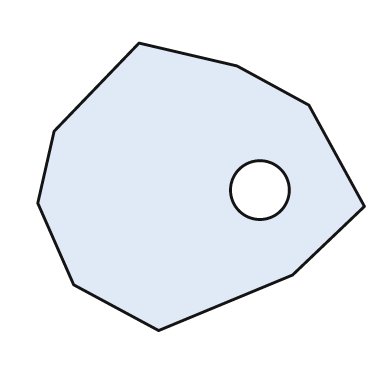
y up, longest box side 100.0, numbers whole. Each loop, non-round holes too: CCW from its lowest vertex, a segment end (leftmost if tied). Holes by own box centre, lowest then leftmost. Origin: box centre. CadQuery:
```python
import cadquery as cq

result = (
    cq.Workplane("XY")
    .moveTo(-13.0, -44.0)
    .lineTo(28.0, -27.0)
    .lineTo(50.0, -6.0)
    .lineTo(33.0, 25.0)
    .lineTo(11.0, 37.0)
    .lineTo(-19.0, 44.0)
    .lineTo(-45.0, 17.0)
    .lineTo(-50.0, -5.0)
    .lineTo(-39.0, -30.0)
    .close()
    .moveTo(18.0, -1.0)
    .circle(9.0)
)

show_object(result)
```